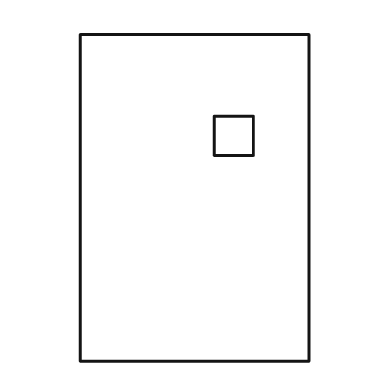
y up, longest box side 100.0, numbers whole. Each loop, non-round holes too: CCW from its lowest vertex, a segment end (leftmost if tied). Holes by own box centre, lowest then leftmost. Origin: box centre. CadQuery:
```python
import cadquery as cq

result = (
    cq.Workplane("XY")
    .moveTo(-35.0, -50.0)
    .lineTo(35.0, -50.0)
    .lineTo(35.0, 50.0)
    .lineTo(-35.0, 50.0)
    .close()
    .moveTo(6.0, 13.0)
    .lineTo(18.0, 13.0)
    .lineTo(18.0, 25.0)
    .lineTo(6.0, 25.0)
    .close()
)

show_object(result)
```